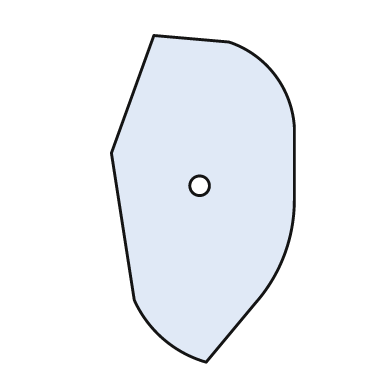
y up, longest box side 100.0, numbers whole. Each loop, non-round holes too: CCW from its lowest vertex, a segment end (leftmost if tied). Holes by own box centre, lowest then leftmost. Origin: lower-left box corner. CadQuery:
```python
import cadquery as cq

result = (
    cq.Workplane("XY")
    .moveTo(29.0, 0.0)
    .lineTo(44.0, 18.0)
    .threePointArc((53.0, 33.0), (56.0, 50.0))
    .lineTo(56.0, 72.0)
    .threePointArc((50.0, 88.0), (36.0, 98.0))
    .lineTo(13.0, 100.0)
    .lineTo(0.0, 64.0)
    .lineTo(7.0, 19.0)
    .threePointArc((16.0, 7.0), (29.0, 0.0))
    .close()
    .moveTo(27.0, 54.0)
    .circle(3.0)
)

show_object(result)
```